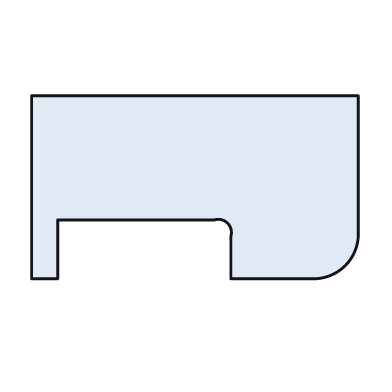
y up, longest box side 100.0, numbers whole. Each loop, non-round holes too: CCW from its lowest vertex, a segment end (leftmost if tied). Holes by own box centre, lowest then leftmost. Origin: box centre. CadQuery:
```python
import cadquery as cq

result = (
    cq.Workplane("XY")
    .moveTo(-50.0, -28.0)
    .lineTo(-42.0, -28.0)
    .lineTo(-42.0, -10.0)
    .lineTo(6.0, -10.0)
    .threePointArc((10.0, -11.0), (11.0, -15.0))
    .lineTo(11.0, -28.0)
    .lineTo(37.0, -28.0)
    .threePointArc((46.0, -24.0), (50.0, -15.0))
    .lineTo(50.0, 28.0)
    .lineTo(-50.0, 28.0)
    .close()
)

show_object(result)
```